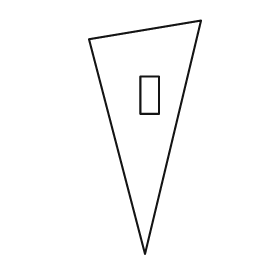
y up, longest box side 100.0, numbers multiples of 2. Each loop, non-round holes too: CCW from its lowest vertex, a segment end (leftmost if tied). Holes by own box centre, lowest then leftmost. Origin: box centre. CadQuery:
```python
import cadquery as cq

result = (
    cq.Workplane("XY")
    .moveTo(0.0, -50.0)
    .lineTo(24.0, 50.0)
    .lineTo(-24.0, 42.0)
    .close()
    .moveTo(-2.0, 10.0)
    .lineTo(6.0, 10.0)
    .lineTo(6.0, 26.0)
    .lineTo(-2.0, 26.0)
    .close()
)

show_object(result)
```